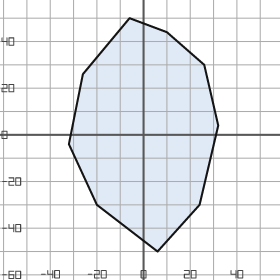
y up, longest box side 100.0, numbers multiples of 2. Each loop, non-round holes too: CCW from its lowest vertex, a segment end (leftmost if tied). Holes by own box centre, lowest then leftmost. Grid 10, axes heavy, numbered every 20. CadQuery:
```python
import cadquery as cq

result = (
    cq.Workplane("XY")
    .moveTo(6.0, -50.0)
    .lineTo(24.0, -30.0)
    .lineTo(32.0, 4.0)
    .lineTo(26.0, 30.0)
    .lineTo(10.0, 44.0)
    .lineTo(-6.0, 50.0)
    .lineTo(-26.0, 26.0)
    .lineTo(-32.0, -4.0)
    .lineTo(-20.0, -30.0)
    .close()
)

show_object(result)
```